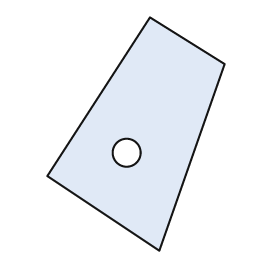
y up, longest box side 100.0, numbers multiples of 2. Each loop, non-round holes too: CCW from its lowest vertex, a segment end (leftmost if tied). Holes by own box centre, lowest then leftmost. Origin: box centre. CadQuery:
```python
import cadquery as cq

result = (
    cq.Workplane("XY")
    .moveTo(10.0, -50.0)
    .lineTo(38.0, 30.0)
    .lineTo(6.0, 50.0)
    .lineTo(-38.0, -18.0)
    .close()
    .moveTo(-4.0, -8.0)
    .circle(6.0)
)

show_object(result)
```